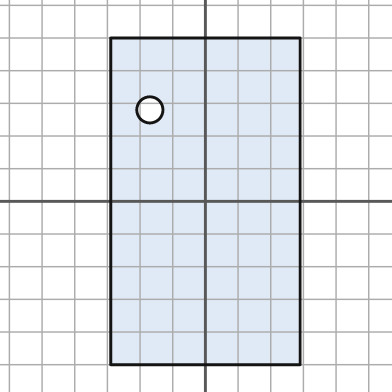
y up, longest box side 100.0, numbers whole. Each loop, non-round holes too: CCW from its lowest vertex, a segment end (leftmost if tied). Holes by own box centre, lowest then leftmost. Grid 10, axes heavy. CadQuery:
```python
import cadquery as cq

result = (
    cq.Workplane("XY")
    .moveTo(-29.0, -50.0)
    .lineTo(29.0, -50.0)
    .lineTo(29.0, 50.0)
    .lineTo(-29.0, 50.0)
    .close()
    .moveTo(-17.0, 28.0)
    .circle(4.0)
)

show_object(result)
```